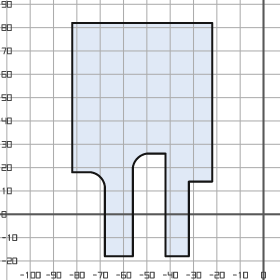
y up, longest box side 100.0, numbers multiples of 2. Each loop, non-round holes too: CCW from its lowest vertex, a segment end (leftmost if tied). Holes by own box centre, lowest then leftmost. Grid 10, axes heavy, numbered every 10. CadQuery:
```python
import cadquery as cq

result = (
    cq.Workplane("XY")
    .moveTo(-68.0, -18.0)
    .lineTo(-56.0, -18.0)
    .lineTo(-56.0, 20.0)
    .threePointArc((-54.0, 24.0), (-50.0, 26.0))
    .lineTo(-42.0, 26.0)
    .lineTo(-42.0, -18.0)
    .lineTo(-32.0, -18.0)
    .lineTo(-32.0, 14.0)
    .lineTo(-22.0, 14.0)
    .lineTo(-22.0, 82.0)
    .lineTo(-82.0, 82.0)
    .lineTo(-82.0, 18.0)
    .lineTo(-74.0, 18.0)
    .threePointArc((-70.0, 16.0), (-68.0, 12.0))
    .close()
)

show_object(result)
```